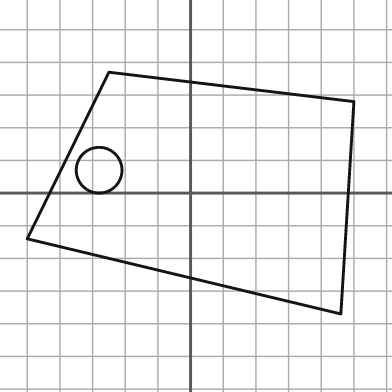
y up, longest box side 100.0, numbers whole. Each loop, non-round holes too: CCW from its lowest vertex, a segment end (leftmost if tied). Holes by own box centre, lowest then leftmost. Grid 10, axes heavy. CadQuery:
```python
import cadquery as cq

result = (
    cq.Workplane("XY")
    .moveTo(46.0, -37.0)
    .lineTo(50.0, 28.0)
    .lineTo(-25.0, 37.0)
    .lineTo(-50.0, -14.0)
    .close()
    .moveTo(-28.0, 7.0)
    .circle(7.0)
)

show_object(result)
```